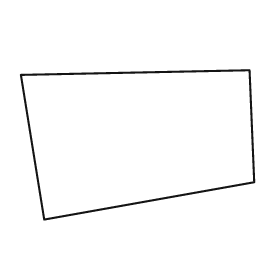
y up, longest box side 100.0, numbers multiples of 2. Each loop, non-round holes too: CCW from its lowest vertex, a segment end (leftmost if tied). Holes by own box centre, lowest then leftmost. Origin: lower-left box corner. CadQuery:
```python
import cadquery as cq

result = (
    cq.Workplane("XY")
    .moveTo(10.0, 0.0)
    .lineTo(100.0, 16.0)
    .lineTo(98.0, 64.0)
    .lineTo(0.0, 62.0)
    .close()
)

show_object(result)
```